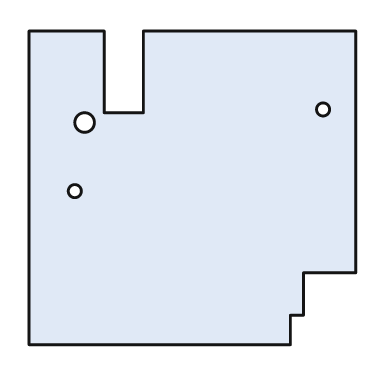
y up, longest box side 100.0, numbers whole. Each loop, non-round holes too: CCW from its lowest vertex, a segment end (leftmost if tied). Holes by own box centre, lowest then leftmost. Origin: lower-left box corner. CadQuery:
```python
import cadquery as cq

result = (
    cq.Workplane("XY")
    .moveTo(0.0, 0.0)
    .lineTo(80.0, 0.0)
    .lineTo(80.0, 9.0)
    .lineTo(84.0, 9.0)
    .lineTo(84.0, 22.0)
    .lineTo(100.0, 22.0)
    .lineTo(100.0, 96.0)
    .lineTo(35.0, 96.0)
    .lineTo(35.0, 71.0)
    .lineTo(23.0, 71.0)
    .lineTo(23.0, 96.0)
    .lineTo(0.0, 96.0)
    .close()
    .moveTo(14.0, 47.0)
    .circle(2.0)
    .moveTo(17.0, 68.0)
    .circle(3.0)
    .moveTo(90.0, 72.0)
    .circle(2.0)
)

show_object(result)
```